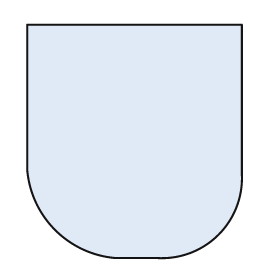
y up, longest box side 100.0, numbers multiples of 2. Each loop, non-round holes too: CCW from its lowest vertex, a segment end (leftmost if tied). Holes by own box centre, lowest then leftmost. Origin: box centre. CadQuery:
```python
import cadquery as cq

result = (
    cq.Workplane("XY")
    .moveTo(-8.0, -50.0)
    .lineTo(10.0, -50.0)
    .threePointArc((36.0, -40.0), (46.0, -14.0))
    .lineTo(46.0, 50.0)
    .lineTo(-46.0, 50.0)
    .lineTo(-46.0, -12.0)
    .threePointArc((-34.0, -38.0), (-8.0, -50.0))
    .close()
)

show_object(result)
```